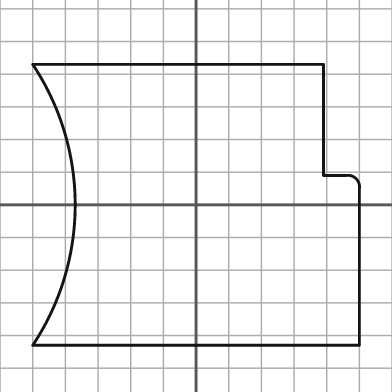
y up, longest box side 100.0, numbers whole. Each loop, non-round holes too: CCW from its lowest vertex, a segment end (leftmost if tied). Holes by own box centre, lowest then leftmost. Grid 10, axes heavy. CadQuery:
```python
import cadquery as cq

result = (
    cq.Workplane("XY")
    .moveTo(-50.0, -43.0)
    .lineTo(50.0, -43.0)
    .lineTo(50.0, 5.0)
    .threePointArc((49.0, 8.0), (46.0, 9.0))
    .lineTo(39.0, 9.0)
    .lineTo(39.0, 43.0)
    .lineTo(-50.0, 43.0)
    .threePointArc((-37.0, 0.0), (-50.0, -43.0))
    .close()
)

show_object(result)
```